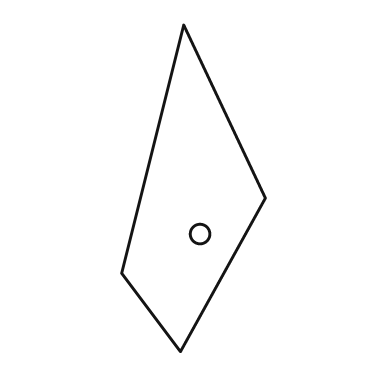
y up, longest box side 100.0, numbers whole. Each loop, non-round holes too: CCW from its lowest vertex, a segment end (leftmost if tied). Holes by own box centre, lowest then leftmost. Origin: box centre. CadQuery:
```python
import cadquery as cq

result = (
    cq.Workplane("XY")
    .moveTo(-4.0, -50.0)
    .lineTo(22.0, -3.0)
    .lineTo(-3.0, 50.0)
    .lineTo(-22.0, -26.0)
    .close()
    .moveTo(2.0, -14.0)
    .circle(3.0)
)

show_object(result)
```